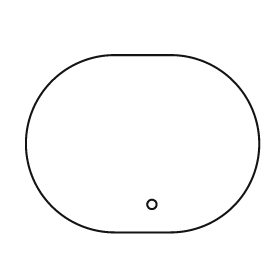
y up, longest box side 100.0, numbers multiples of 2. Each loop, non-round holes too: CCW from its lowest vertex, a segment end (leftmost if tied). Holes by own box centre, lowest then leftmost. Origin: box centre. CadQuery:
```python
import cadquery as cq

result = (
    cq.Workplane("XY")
    .moveTo(-12.0, -38.0)
    .lineTo(12.0, -38.0)
    .threePointArc((50.0, 0.0), (12.0, 38.0))
    .lineTo(-12.0, 38.0)
    .threePointArc((-50.0, 0.0), (-12.0, -38.0))
    .close()
    .moveTo(4.0, -26.0)
    .circle(2.0)
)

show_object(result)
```